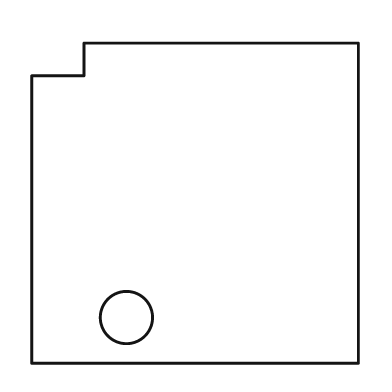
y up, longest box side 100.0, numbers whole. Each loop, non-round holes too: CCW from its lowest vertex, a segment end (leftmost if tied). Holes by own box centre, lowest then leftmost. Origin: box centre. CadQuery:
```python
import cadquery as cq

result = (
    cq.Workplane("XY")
    .moveTo(-50.0, -49.0)
    .lineTo(50.0, -49.0)
    .lineTo(50.0, 49.0)
    .lineTo(-34.0, 49.0)
    .lineTo(-34.0, 39.0)
    .lineTo(-50.0, 39.0)
    .close()
    .moveTo(-21.0, -35.0)
    .circle(8.0)
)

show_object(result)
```